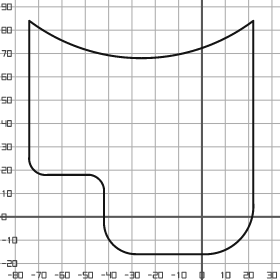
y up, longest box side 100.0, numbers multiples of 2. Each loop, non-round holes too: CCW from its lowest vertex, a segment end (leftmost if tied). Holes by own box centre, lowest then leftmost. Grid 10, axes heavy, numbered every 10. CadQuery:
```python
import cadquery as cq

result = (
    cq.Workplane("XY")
    .moveTo(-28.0, -16.0)
    .lineTo(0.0, -16.0)
    .threePointArc((16.0, -10.0), (22.0, 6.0))
    .lineTo(22.0, 84.0)
    .threePointArc((-26.0, 68.0), (-74.0, 84.0))
    .lineTo(-74.0, 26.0)
    .threePointArc((-72.0, 20.0), (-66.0, 18.0))
    .lineTo(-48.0, 18.0)
    .threePointArc((-44.0, 16.0), (-42.0, 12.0))
    .lineTo(-42.0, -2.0)
    .threePointArc((-38.0, -12.0), (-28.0, -16.0))
    .close()
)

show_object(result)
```